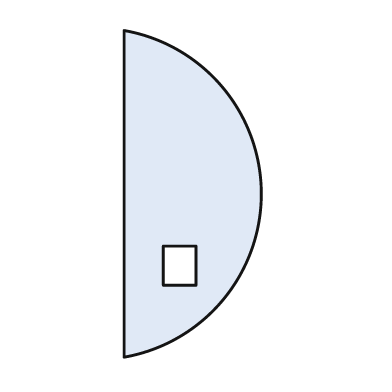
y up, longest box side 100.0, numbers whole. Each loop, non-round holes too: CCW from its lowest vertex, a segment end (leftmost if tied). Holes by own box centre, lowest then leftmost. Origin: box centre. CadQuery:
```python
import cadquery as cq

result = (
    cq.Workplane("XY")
    .moveTo(-21.0, -50.0)
    .threePointArc((21.0, 0.0), (-21.0, 50.0))
    .close()
    .moveTo(-9.0, -28.0)
    .lineTo(1.0, -28.0)
    .lineTo(1.0, -16.0)
    .lineTo(-9.0, -16.0)
    .close()
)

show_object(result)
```